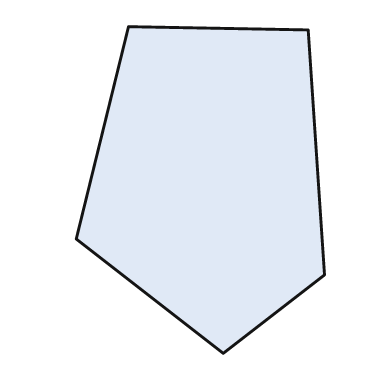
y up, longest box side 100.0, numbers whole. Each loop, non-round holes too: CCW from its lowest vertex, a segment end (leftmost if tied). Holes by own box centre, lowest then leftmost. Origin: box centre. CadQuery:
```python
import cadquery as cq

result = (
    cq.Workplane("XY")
    .moveTo(7.0, -50.0)
    .lineTo(38.0, -26.0)
    .lineTo(33.0, 49.0)
    .lineTo(-22.0, 50.0)
    .lineTo(-38.0, -15.0)
    .close()
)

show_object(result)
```